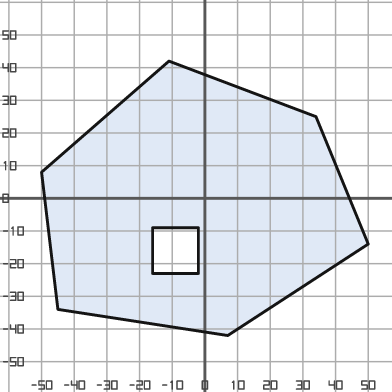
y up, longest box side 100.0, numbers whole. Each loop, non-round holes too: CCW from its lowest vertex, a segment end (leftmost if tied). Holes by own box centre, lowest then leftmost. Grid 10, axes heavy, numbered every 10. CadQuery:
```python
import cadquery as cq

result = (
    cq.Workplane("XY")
    .moveTo(7.0, -42.0)
    .lineTo(50.0, -14.0)
    .lineTo(34.0, 25.0)
    .lineTo(-11.0, 42.0)
    .lineTo(-50.0, 8.0)
    .lineTo(-45.0, -34.0)
    .close()
    .moveTo(-16.0, -23.0)
    .lineTo(-2.0, -23.0)
    .lineTo(-2.0, -9.0)
    .lineTo(-16.0, -9.0)
    .close()
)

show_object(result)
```